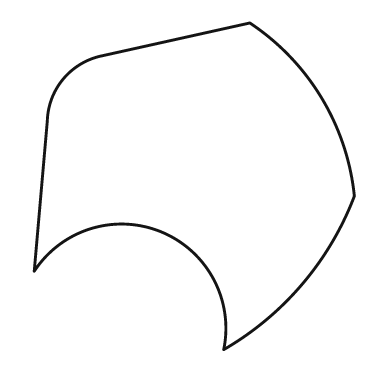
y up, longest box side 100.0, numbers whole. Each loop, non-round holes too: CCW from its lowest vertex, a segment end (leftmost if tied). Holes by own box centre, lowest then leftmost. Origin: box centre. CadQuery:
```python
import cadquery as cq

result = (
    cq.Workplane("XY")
    .moveTo(9.0, -50.0)
    .threePointArc((33.0, -30.0), (49.0, -3.0))
    .threePointArc((39.0, 27.0), (17.0, 50.0))
    .lineTo(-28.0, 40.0)
    .threePointArc((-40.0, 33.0), (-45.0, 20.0))
    .lineTo(-49.0, -26.0)
    .threePointArc((-10.0, -14.0), (9.0, -50.0))
    .close()
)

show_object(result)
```